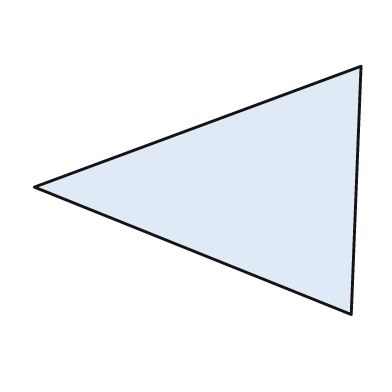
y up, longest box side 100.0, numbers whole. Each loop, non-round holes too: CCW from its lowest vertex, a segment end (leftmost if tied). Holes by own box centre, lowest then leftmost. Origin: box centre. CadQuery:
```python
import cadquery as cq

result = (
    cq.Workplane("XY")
    .moveTo(47.0, -38.0)
    .lineTo(50.0, 38.0)
    .lineTo(-50.0, 1.0)
    .close()
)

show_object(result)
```